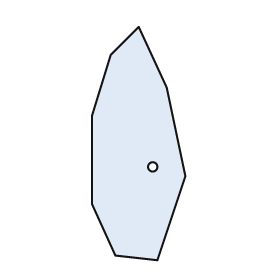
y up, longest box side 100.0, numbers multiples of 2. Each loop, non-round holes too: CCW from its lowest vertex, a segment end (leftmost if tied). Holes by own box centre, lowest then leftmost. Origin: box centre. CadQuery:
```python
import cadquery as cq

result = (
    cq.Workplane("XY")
    .moveTo(8.0, -50.0)
    .lineTo(20.0, -14.0)
    .lineTo(12.0, 24.0)
    .lineTo(0.0, 50.0)
    .lineTo(-12.0, 38.0)
    .lineTo(-20.0, 12.0)
    .lineTo(-20.0, -26.0)
    .lineTo(-10.0, -48.0)
    .close()
    .moveTo(6.0, -10.0)
    .circle(2.0)
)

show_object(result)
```